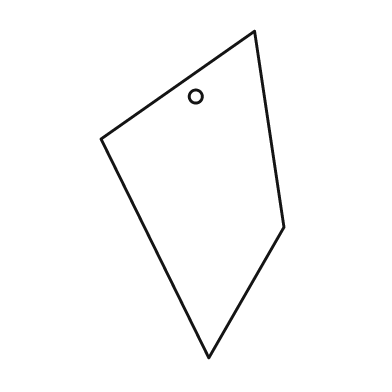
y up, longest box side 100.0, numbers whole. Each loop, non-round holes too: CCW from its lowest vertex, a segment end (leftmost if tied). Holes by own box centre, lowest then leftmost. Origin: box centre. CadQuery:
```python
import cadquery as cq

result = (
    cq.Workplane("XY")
    .moveTo(5.0, -50.0)
    .lineTo(28.0, -10.0)
    .lineTo(19.0, 50.0)
    .lineTo(-28.0, 17.0)
    .close()
    .moveTo(1.0, 30.0)
    .circle(2.0)
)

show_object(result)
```